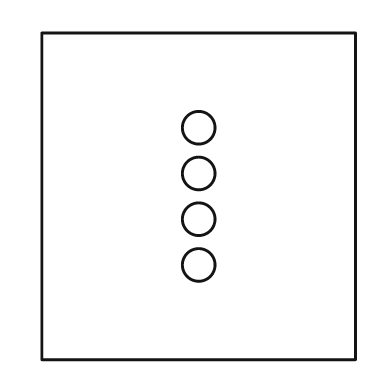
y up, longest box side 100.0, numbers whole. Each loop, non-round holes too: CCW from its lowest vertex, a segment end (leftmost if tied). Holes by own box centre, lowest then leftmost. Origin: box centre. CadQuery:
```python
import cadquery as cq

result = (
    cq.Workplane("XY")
    .moveTo(-48.0, -50.0)
    .lineTo(48.0, -50.0)
    .lineTo(48.0, 50.0)
    .lineTo(-48.0, 50.0)
    .close()
    .moveTo(0.0, -21.0)
    .circle(5.0)
    .moveTo(0.0, -7.0)
    .circle(5.0)
    .moveTo(0.0, 7.0)
    .circle(5.0)
    .moveTo(0.0, 21.0)
    .circle(5.0)
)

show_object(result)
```